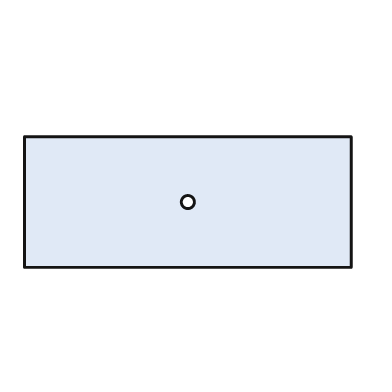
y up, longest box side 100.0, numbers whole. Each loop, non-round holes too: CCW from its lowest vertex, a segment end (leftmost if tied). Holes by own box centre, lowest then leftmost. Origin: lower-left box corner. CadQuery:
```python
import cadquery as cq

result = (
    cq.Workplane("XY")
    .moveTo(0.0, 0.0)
    .lineTo(100.0, 0.0)
    .lineTo(100.0, 40.0)
    .lineTo(0.0, 40.0)
    .close()
    .moveTo(50.0, 20.0)
    .circle(2.0)
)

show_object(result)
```